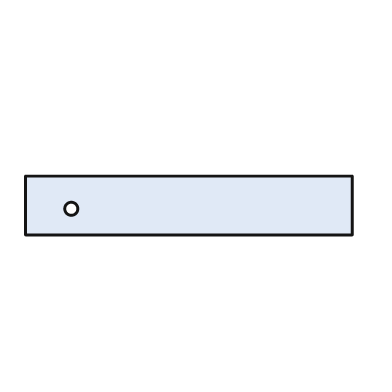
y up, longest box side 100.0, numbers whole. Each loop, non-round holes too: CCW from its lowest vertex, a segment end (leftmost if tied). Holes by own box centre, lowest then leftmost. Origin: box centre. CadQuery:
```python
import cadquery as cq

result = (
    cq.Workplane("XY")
    .moveTo(-50.0, -9.0)
    .lineTo(50.0, -9.0)
    .lineTo(50.0, 9.0)
    .lineTo(-50.0, 9.0)
    .close()
    .moveTo(-36.0, -1.0)
    .circle(2.0)
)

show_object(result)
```